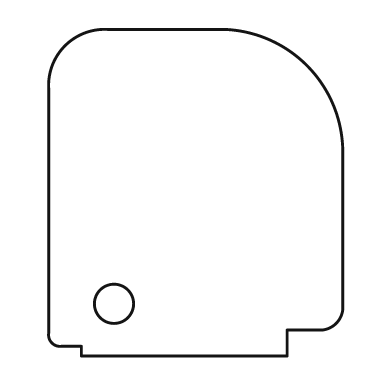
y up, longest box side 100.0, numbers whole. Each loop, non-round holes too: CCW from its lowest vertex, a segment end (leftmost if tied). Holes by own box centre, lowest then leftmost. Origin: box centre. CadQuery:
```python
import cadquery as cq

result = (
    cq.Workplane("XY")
    .moveTo(-35.0, -50.0)
    .lineTo(28.0, -50.0)
    .lineTo(28.0, -42.0)
    .lineTo(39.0, -42.0)
    .threePointArc((43.0, -40.0), (45.0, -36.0))
    .lineTo(45.0, 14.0)
    .threePointArc((34.0, 39.0), (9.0, 50.0))
    .lineTo(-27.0, 50.0)
    .threePointArc((-40.0, 45.0), (-45.0, 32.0))
    .lineTo(-45.0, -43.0)
    .threePointArc((-44.0, -46.0), (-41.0, -47.0))
    .lineTo(-35.0, -47.0)
    .close()
    .moveTo(-25.0, -34.0)
    .circle(6.0)
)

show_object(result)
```